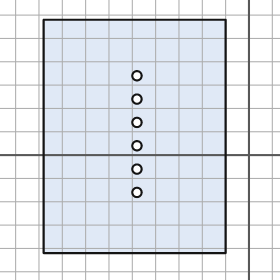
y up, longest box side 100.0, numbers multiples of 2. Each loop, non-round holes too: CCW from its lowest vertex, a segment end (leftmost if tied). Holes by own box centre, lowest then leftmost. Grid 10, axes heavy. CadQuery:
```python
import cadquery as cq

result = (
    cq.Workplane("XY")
    .moveTo(-88.0, -42.0)
    .lineTo(-10.0, -42.0)
    .lineTo(-10.0, 58.0)
    .lineTo(-88.0, 58.0)
    .close()
    .moveTo(-48.0, -16.0)
    .circle(2.0)
    .moveTo(-48.0, -6.0)
    .circle(2.0)
    .moveTo(-48.0, 4.0)
    .circle(2.0)
    .moveTo(-48.0, 14.0)
    .circle(2.0)
    .moveTo(-48.0, 24.0)
    .circle(2.0)
    .moveTo(-48.0, 34.0)
    .circle(2.0)
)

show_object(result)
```